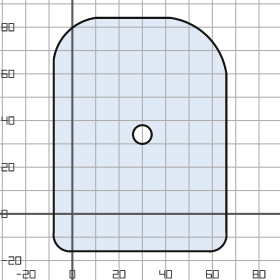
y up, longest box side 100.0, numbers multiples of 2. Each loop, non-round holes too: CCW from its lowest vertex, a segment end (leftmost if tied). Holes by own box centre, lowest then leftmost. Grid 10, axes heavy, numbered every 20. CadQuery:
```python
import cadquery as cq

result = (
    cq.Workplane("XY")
    .moveTo(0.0, -16.0)
    .lineTo(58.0, -16.0)
    .threePointArc((64.0, -14.0), (66.0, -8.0))
    .lineTo(66.0, 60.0)
    .threePointArc((58.0, 76.0), (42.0, 84.0))
    .lineTo(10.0, 84.0)
    .threePointArc((-2.0, 78.0), (-8.0, 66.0))
    .lineTo(-8.0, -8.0)
    .threePointArc((-6.0, -14.0), (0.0, -16.0))
    .close()
    .moveTo(30.0, 34.0)
    .circle(4.0)
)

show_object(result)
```